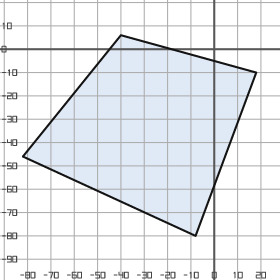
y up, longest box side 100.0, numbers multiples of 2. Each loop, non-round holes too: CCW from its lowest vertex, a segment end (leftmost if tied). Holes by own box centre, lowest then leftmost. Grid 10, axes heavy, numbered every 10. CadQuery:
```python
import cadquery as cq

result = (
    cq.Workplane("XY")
    .moveTo(-8.0, -80.0)
    .lineTo(18.0, -10.0)
    .lineTo(-40.0, 6.0)
    .lineTo(-82.0, -46.0)
    .close()
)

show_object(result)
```